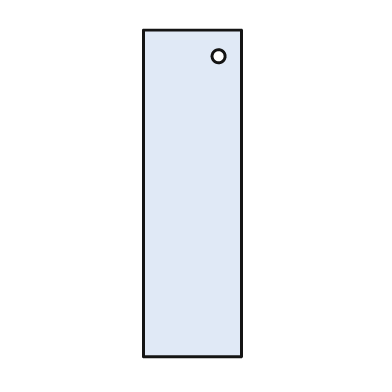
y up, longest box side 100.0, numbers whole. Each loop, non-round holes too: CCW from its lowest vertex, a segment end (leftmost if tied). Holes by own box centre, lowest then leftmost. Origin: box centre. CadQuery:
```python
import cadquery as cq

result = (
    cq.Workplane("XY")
    .moveTo(-15.0, -50.0)
    .lineTo(15.0, -50.0)
    .lineTo(15.0, 50.0)
    .lineTo(-15.0, 50.0)
    .close()
    .moveTo(8.0, 42.0)
    .circle(2.0)
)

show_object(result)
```